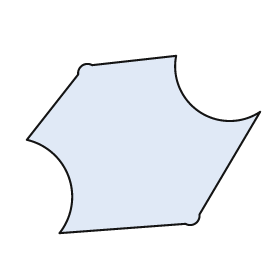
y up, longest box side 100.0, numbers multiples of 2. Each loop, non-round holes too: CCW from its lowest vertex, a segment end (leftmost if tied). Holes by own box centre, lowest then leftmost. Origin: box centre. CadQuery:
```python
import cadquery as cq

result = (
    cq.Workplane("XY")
    .moveTo(-36.0, -38.0)
    .lineTo(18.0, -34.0)
    .threePointArc((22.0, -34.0), (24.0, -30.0))
    .lineTo(50.0, 14.0)
    .threePointArc((24.0, 14.0), (14.0, 38.0))
    .lineTo(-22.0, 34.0)
    .threePointArc((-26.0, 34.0), (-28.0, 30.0))
    .lineTo(-50.0, 2.0)
    .threePointArc((-32.0, -14.0), (-36.0, -38.0))
    .close()
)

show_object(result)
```